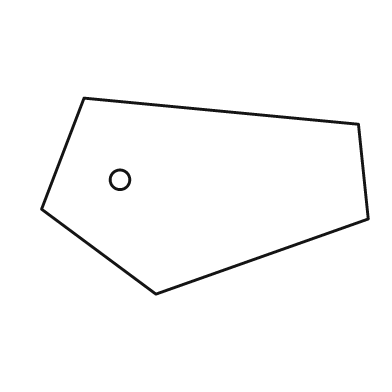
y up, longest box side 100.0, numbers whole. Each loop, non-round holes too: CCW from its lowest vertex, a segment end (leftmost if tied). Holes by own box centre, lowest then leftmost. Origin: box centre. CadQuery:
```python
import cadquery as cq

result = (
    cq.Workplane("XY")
    .moveTo(-15.0, -30.0)
    .lineTo(50.0, -7.0)
    .lineTo(47.0, 22.0)
    .lineTo(-37.0, 30.0)
    .lineTo(-50.0, -4.0)
    .close()
    .moveTo(-26.0, 5.0)
    .circle(3.0)
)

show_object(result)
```